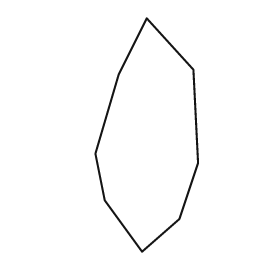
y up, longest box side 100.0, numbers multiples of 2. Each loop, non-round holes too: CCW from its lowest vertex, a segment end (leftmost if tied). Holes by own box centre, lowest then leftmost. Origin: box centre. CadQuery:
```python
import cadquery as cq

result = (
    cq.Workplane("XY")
    .moveTo(-2.0, -50.0)
    .lineTo(14.0, -36.0)
    .lineTo(22.0, -12.0)
    .lineTo(20.0, 28.0)
    .lineTo(0.0, 50.0)
    .lineTo(-12.0, 26.0)
    .lineTo(-22.0, -8.0)
    .lineTo(-18.0, -28.0)
    .close()
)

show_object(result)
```